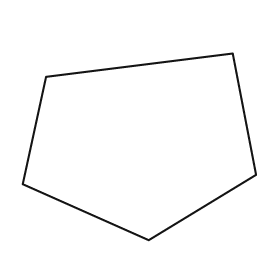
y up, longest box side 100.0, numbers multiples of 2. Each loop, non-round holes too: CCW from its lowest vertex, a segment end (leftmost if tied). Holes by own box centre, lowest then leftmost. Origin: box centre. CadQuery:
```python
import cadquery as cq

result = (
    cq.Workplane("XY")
    .moveTo(4.0, -40.0)
    .lineTo(50.0, -12.0)
    .lineTo(40.0, 40.0)
    .lineTo(-40.0, 30.0)
    .lineTo(-50.0, -16.0)
    .close()
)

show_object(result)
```